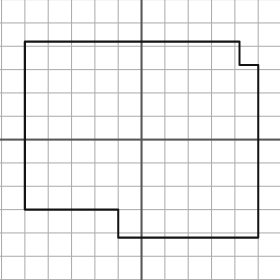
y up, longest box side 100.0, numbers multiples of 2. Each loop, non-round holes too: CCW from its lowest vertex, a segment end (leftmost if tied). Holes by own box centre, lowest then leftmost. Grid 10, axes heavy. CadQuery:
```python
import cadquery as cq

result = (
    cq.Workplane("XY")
    .moveTo(-10.0, -42.0)
    .lineTo(50.0, -42.0)
    .lineTo(50.0, 32.0)
    .lineTo(42.0, 32.0)
    .lineTo(42.0, 42.0)
    .lineTo(-50.0, 42.0)
    .lineTo(-50.0, -30.0)
    .lineTo(-10.0, -30.0)
    .close()
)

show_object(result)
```